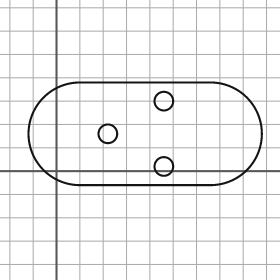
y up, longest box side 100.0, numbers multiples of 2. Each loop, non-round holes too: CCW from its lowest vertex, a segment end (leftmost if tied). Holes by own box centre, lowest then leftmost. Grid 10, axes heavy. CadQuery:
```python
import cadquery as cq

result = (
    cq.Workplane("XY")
    .moveTo(10.0, -6.0)
    .lineTo(66.0, -6.0)
    .threePointArc((88.0, 16.0), (66.0, 38.0))
    .lineTo(10.0, 38.0)
    .threePointArc((-12.0, 16.0), (10.0, -6.0))
    .close()
    .moveTo(46.0, 2.0)
    .circle(4.0)
    .moveTo(22.0, 16.0)
    .circle(4.0)
    .moveTo(46.0, 30.0)
    .circle(4.0)
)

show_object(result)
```